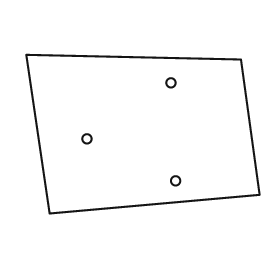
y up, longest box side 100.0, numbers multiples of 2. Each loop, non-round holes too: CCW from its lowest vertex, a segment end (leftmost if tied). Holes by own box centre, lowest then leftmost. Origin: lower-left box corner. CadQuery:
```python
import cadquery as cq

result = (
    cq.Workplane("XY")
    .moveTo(10.0, 0.0)
    .lineTo(100.0, 8.0)
    .lineTo(92.0, 66.0)
    .lineTo(0.0, 68.0)
    .close()
    .moveTo(64.0, 14.0)
    .circle(2.0)
    .moveTo(26.0, 32.0)
    .circle(2.0)
    .moveTo(62.0, 56.0)
    .circle(2.0)
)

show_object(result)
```